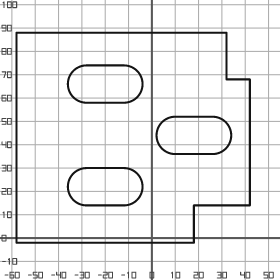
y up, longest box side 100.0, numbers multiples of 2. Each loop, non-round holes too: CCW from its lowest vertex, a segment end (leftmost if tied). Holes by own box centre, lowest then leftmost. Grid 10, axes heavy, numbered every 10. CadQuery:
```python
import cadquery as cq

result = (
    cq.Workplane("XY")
    .moveTo(-58.0, -2.0)
    .lineTo(18.0, -2.0)
    .lineTo(18.0, 14.0)
    .lineTo(42.0, 14.0)
    .lineTo(42.0, 68.0)
    .lineTo(32.0, 68.0)
    .lineTo(32.0, 88.0)
    .lineTo(-58.0, 88.0)
    .close()
    .moveTo(-28.0, 14.0)
    .lineTo(-12.0, 14.0)
    .threePointArc((-4.0, 22.0), (-12.0, 30.0))
    .lineTo(-28.0, 30.0)
    .threePointArc((-36.0, 22.0), (-28.0, 14.0))
    .close()
    .moveTo(10.0, 36.0)
    .lineTo(26.0, 36.0)
    .threePointArc((34.0, 44.0), (26.0, 52.0))
    .lineTo(10.0, 52.0)
    .threePointArc((2.0, 44.0), (10.0, 36.0))
    .close()
    .moveTo(-28.0, 58.0)
    .lineTo(-12.0, 58.0)
    .threePointArc((-4.0, 66.0), (-12.0, 74.0))
    .lineTo(-28.0, 74.0)
    .threePointArc((-36.0, 66.0), (-28.0, 58.0))
    .close()
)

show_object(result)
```